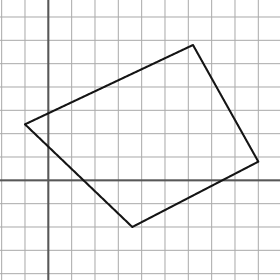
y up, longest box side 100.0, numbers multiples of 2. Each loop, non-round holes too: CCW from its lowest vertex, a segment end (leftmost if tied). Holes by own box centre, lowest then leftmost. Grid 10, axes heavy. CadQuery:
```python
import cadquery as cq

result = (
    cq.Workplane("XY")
    .moveTo(36.0, -20.0)
    .lineTo(90.0, 8.0)
    .lineTo(62.0, 58.0)
    .lineTo(-10.0, 24.0)
    .close()
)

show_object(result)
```